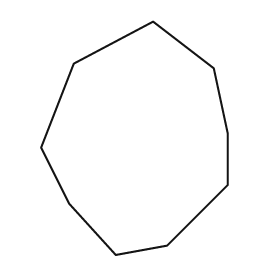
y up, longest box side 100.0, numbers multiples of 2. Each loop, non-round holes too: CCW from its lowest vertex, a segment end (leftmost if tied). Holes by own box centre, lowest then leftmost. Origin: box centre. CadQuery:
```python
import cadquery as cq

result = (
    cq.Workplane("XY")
    .moveTo(-8.0, -50.0)
    .lineTo(14.0, -46.0)
    .lineTo(40.0, -20.0)
    .lineTo(40.0, 2.0)
    .lineTo(34.0, 30.0)
    .lineTo(8.0, 50.0)
    .lineTo(-26.0, 32.0)
    .lineTo(-40.0, -4.0)
    .lineTo(-28.0, -28.0)
    .close()
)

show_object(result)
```